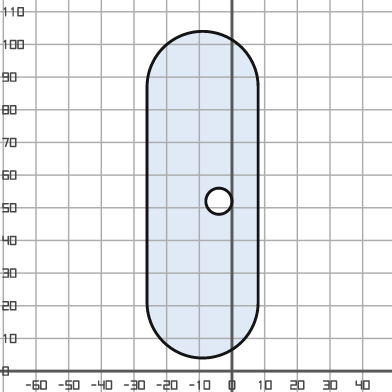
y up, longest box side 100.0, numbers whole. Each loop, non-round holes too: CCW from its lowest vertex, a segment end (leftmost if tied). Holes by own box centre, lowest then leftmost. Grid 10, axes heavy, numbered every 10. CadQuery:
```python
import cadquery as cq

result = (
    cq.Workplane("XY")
    .moveTo(-26.0, 21.0)
    .threePointArc((-9.0, 4.0), (8.0, 21.0))
    .lineTo(8.0, 87.0)
    .threePointArc((-9.0, 104.0), (-26.0, 87.0))
    .close()
    .moveTo(-4.0, 52.0)
    .circle(4.0)
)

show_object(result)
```